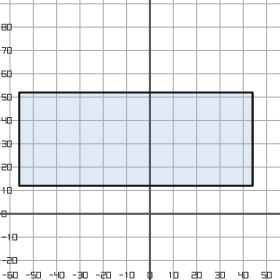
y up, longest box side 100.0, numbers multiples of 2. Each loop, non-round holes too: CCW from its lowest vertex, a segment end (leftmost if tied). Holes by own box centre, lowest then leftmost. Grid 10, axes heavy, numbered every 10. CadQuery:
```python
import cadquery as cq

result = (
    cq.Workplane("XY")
    .moveTo(-56.0, 12.0)
    .lineTo(44.0, 12.0)
    .lineTo(44.0, 52.0)
    .lineTo(-56.0, 52.0)
    .close()
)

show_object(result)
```